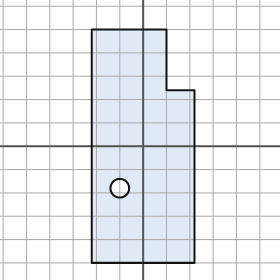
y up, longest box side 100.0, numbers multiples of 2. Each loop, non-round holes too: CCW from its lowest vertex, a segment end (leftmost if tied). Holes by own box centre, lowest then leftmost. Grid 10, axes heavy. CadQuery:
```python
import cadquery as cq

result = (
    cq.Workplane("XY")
    .moveTo(-22.0, -50.0)
    .lineTo(22.0, -50.0)
    .lineTo(22.0, 24.0)
    .lineTo(10.0, 24.0)
    .lineTo(10.0, 50.0)
    .lineTo(-22.0, 50.0)
    .close()
    .moveTo(-10.0, -18.0)
    .circle(4.0)
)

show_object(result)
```